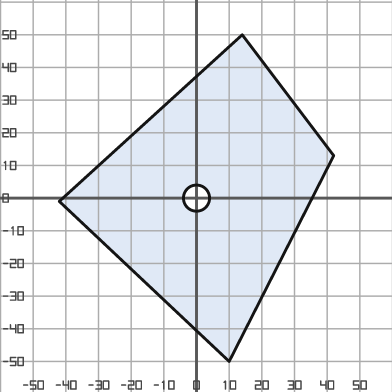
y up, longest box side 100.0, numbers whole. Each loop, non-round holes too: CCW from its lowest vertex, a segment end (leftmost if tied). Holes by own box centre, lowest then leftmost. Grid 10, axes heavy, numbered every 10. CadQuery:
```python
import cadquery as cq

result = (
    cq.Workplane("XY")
    .moveTo(10.0, -50.0)
    .lineTo(42.0, 13.0)
    .lineTo(14.0, 50.0)
    .lineTo(-42.0, -1.0)
    .close()
    .moveTo(0.0, 0.0)
    .circle(4.0)
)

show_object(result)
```